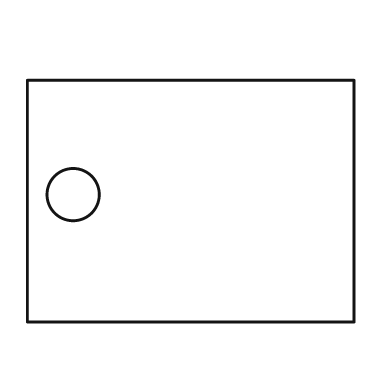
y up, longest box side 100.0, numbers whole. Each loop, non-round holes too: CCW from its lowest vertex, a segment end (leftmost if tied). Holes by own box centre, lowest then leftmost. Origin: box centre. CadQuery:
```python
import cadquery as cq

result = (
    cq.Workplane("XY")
    .moveTo(-50.0, -37.0)
    .lineTo(50.0, -37.0)
    .lineTo(50.0, 37.0)
    .lineTo(-50.0, 37.0)
    .close()
    .moveTo(-36.0, 2.0)
    .circle(8.0)
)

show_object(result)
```